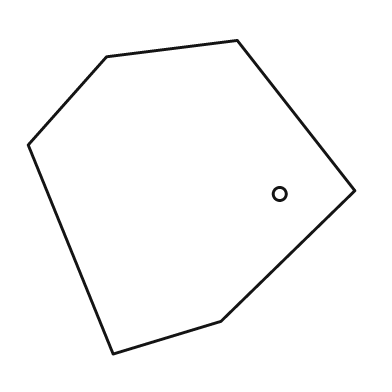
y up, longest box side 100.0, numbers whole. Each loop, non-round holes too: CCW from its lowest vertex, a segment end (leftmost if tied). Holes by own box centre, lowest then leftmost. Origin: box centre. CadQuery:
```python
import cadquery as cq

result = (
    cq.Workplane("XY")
    .moveTo(-24.0, -48.0)
    .lineTo(9.0, -38.0)
    .lineTo(50.0, 2.0)
    .lineTo(14.0, 48.0)
    .lineTo(-26.0, 43.0)
    .lineTo(-50.0, 16.0)
    .close()
    .moveTo(27.0, 1.0)
    .circle(2.0)
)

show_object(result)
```